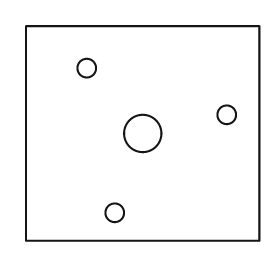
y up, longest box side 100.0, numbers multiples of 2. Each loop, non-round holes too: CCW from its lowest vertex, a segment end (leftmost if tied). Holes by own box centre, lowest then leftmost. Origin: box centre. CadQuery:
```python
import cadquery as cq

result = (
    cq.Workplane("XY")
    .moveTo(-50.0, -46.0)
    .lineTo(50.0, -46.0)
    .lineTo(50.0, 46.0)
    .lineTo(-50.0, 46.0)
    .close()
    .moveTo(-12.0, -34.0)
    .circle(4.0)
    .moveTo(0.0, 0.0)
    .circle(8.0)
    .moveTo(36.0, 8.0)
    .circle(4.0)
    .moveTo(-24.0, 28.0)
    .circle(4.0)
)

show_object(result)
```